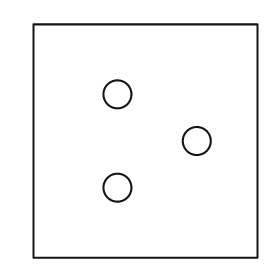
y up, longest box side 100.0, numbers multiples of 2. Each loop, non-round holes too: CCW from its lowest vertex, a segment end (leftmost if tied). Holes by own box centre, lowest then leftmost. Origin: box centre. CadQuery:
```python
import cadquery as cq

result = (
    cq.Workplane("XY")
    .moveTo(-48.0, -50.0)
    .lineTo(48.0, -50.0)
    .lineTo(48.0, 50.0)
    .lineTo(-48.0, 50.0)
    .close()
    .moveTo(-12.0, -20.0)
    .circle(6.0)
    .moveTo(22.0, 0.0)
    .circle(6.0)
    .moveTo(-12.0, 20.0)
    .circle(6.0)
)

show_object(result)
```